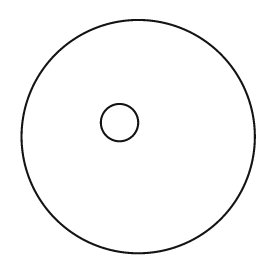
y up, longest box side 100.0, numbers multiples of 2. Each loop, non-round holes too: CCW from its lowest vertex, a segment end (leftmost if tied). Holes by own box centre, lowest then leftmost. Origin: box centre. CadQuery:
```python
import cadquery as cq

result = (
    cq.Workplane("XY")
    .moveTo(0.0, 0.0)
    .circle(50.0)
    .moveTo(-8.0, 6.0)
    .circle(8.0)
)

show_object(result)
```